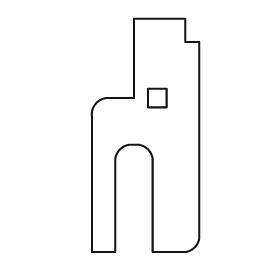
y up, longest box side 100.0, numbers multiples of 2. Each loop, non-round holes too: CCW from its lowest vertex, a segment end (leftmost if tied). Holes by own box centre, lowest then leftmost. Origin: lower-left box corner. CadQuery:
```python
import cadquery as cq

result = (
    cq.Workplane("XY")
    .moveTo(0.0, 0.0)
    .lineTo(10.0, 0.0)
    .lineTo(10.0, 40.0)
    .threePointArc((12.0, 44.0), (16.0, 46.0))
    .lineTo(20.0, 46.0)
    .threePointArc((24.0, 44.0), (26.0, 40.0))
    .lineTo(26.0, 0.0)
    .lineTo(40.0, 0.0)
    .threePointArc((44.0, 2.0), (46.0, 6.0))
    .lineTo(46.0, 90.0)
    .lineTo(40.0, 90.0)
    .lineTo(40.0, 100.0)
    .lineTo(18.0, 100.0)
    .lineTo(18.0, 66.0)
    .lineTo(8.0, 66.0)
    .threePointArc((2.0, 64.0), (0.0, 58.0))
    .close()
    .moveTo(24.0, 62.0)
    .lineTo(32.0, 62.0)
    .lineTo(32.0, 70.0)
    .lineTo(24.0, 70.0)
    .close()
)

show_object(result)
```